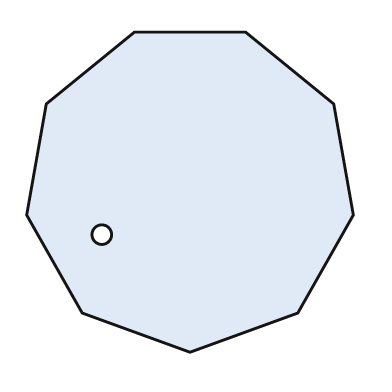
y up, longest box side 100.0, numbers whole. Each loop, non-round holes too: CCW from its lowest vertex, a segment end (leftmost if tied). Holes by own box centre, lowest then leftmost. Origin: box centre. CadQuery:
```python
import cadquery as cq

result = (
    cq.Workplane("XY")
    .moveTo(0.0, -49.0)
    .lineTo(33.0, -37.0)
    .lineTo(50.0, -7.0)
    .lineTo(44.0, 27.0)
    .lineTo(17.0, 49.0)
    .lineTo(-17.0, 49.0)
    .lineTo(-44.0, 27.0)
    .lineTo(-50.0, -7.0)
    .lineTo(-33.0, -37.0)
    .close()
    .moveTo(-27.0, -13.0)
    .circle(3.0)
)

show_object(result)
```